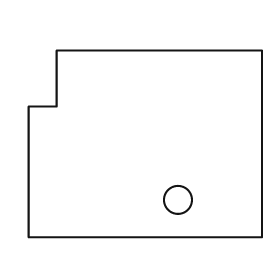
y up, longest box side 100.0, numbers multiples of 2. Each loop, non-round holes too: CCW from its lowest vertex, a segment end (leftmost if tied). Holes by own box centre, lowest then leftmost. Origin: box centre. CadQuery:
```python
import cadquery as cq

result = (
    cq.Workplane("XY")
    .moveTo(-50.0, -40.0)
    .lineTo(50.0, -40.0)
    .lineTo(50.0, 40.0)
    .lineTo(-38.0, 40.0)
    .lineTo(-38.0, 16.0)
    .lineTo(-50.0, 16.0)
    .close()
    .moveTo(14.0, -24.0)
    .circle(6.0)
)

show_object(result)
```